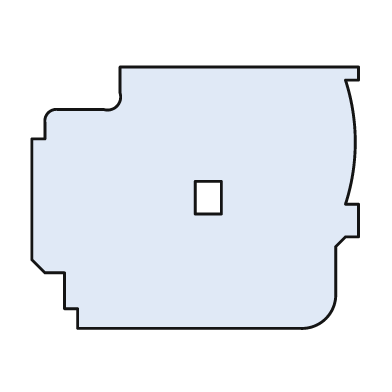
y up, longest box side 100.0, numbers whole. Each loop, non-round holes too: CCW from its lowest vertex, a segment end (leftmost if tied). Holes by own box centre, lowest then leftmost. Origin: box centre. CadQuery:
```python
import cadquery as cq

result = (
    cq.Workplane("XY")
    .moveTo(-36.0, -40.0)
    .lineTo(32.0, -40.0)
    .threePointArc((40.0, -37.0), (43.0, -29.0))
    .lineTo(43.0, -15.0)
    .lineTo(46.0, -12.0)
    .lineTo(50.0, -12.0)
    .lineTo(50.0, -2.0)
    .lineTo(46.0, -2.0)
    .threePointArc((49.0, 17.0), (46.0, 36.0))
    .lineTo(50.0, 36.0)
    .lineTo(50.0, 40.0)
    .lineTo(-23.0, 40.0)
    .lineTo(-23.0, 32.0)
    .threePointArc((-24.0, 28.0), (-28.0, 27.0))
    .lineTo(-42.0, 27.0)
    .threePointArc((-45.0, 26.0), (-46.0, 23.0))
    .lineTo(-46.0, 18.0)
    .lineTo(-50.0, 18.0)
    .lineTo(-50.0, -19.0)
    .lineTo(-46.0, -23.0)
    .lineTo(-40.0, -23.0)
    .lineTo(-40.0, -34.0)
    .lineTo(-36.0, -34.0)
    .close()
    .moveTo(0.0, -5.0)
    .lineTo(8.0, -5.0)
    .lineTo(8.0, 5.0)
    .lineTo(0.0, 5.0)
    .close()
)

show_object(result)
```